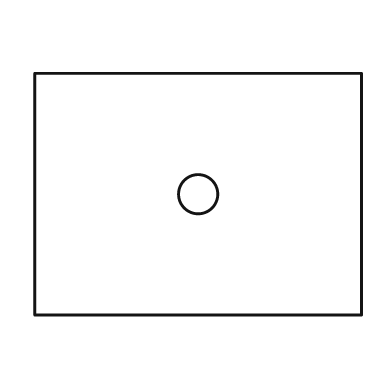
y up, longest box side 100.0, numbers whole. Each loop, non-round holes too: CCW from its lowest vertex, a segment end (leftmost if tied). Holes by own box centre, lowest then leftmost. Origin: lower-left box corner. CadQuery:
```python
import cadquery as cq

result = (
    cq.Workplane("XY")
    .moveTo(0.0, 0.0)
    .lineTo(100.0, 0.0)
    .lineTo(100.0, 74.0)
    .lineTo(0.0, 74.0)
    .close()
    .moveTo(50.0, 37.0)
    .circle(6.0)
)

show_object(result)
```